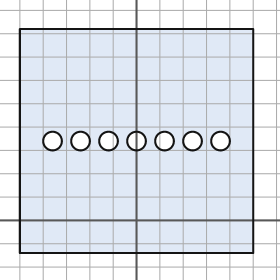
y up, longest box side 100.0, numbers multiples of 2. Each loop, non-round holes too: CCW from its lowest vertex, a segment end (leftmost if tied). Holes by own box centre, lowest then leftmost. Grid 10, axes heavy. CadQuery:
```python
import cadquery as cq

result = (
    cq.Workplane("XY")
    .moveTo(-50.0, -14.0)
    .lineTo(50.0, -14.0)
    .lineTo(50.0, 82.0)
    .lineTo(-50.0, 82.0)
    .close()
    .moveTo(-36.0, 34.0)
    .circle(4.0)
    .moveTo(-24.0, 34.0)
    .circle(4.0)
    .moveTo(-12.0, 34.0)
    .circle(4.0)
    .moveTo(0.0, 34.0)
    .circle(4.0)
    .moveTo(12.0, 34.0)
    .circle(4.0)
    .moveTo(24.0, 34.0)
    .circle(4.0)
    .moveTo(36.0, 34.0)
    .circle(4.0)
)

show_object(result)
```